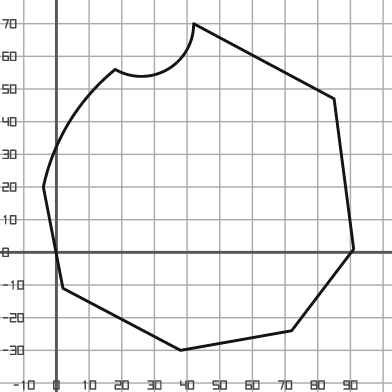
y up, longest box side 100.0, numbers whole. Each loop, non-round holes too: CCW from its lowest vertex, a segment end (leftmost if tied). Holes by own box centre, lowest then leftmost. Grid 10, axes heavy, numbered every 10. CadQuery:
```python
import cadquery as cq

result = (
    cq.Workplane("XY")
    .moveTo(38.0, -30.0)
    .lineTo(72.0, -24.0)
    .lineTo(91.0, 1.0)
    .lineTo(85.0, 47.0)
    .lineTo(42.0, 70.0)
    .threePointArc((34.0, 56.0), (18.0, 56.0))
    .threePointArc((4.0, 40.0), (-4.0, 20.0))
    .lineTo(2.0, -11.0)
    .close()
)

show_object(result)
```